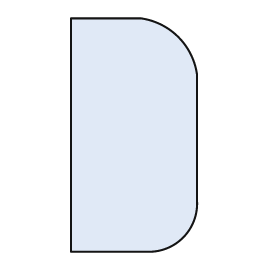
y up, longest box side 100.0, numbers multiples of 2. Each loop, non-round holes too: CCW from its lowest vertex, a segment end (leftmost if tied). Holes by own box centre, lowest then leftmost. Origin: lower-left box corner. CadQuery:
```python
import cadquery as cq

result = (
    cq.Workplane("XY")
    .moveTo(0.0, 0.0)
    .lineTo(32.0, 0.0)
    .threePointArc((48.0, 6.0), (54.0, 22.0))
    .lineTo(54.0, 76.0)
    .threePointArc((46.0, 92.0), (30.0, 100.0))
    .lineTo(0.0, 100.0)
    .close()
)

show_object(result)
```